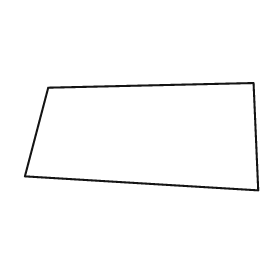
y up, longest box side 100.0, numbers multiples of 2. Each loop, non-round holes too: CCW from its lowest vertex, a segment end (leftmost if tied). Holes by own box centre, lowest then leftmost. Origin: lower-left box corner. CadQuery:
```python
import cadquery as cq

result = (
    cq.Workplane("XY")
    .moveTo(100.0, 0.0)
    .lineTo(98.0, 46.0)
    .lineTo(10.0, 44.0)
    .lineTo(0.0, 6.0)
    .close()
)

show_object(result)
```